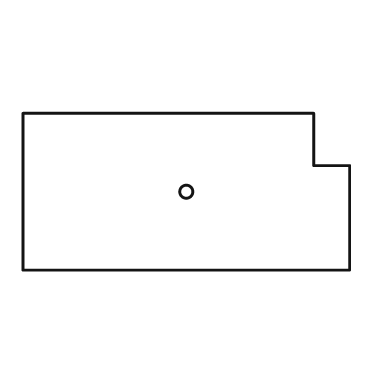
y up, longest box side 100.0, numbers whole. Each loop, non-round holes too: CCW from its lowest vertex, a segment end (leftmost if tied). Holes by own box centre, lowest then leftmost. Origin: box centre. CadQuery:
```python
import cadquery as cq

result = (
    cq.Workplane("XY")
    .moveTo(-50.0, -24.0)
    .lineTo(50.0, -24.0)
    .lineTo(50.0, 8.0)
    .lineTo(39.0, 8.0)
    .lineTo(39.0, 24.0)
    .lineTo(-50.0, 24.0)
    .close()
    .moveTo(0.0, 0.0)
    .circle(2.0)
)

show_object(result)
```